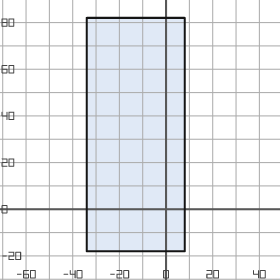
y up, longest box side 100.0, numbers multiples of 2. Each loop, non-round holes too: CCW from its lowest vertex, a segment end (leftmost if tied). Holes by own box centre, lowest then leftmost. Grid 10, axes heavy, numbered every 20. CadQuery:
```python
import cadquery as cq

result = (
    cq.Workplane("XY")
    .moveTo(-34.0, -18.0)
    .lineTo(8.0, -18.0)
    .lineTo(8.0, 82.0)
    .lineTo(-34.0, 82.0)
    .close()
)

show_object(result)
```